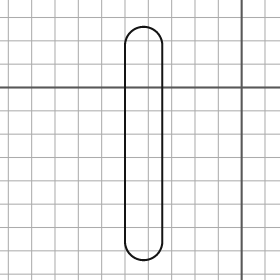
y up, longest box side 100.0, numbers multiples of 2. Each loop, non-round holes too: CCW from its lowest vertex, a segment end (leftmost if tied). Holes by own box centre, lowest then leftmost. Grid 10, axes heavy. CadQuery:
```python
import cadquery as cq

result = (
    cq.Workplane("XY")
    .moveTo(-50.0, -66.0)
    .threePointArc((-42.0, -74.0), (-34.0, -66.0))
    .lineTo(-34.0, 18.0)
    .threePointArc((-42.0, 26.0), (-50.0, 18.0))
    .close()
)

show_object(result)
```